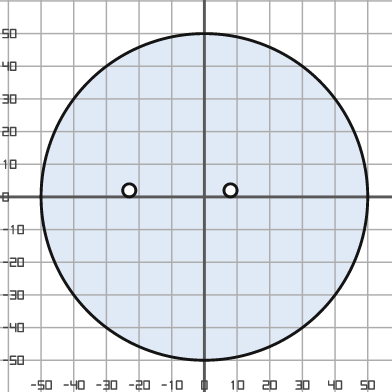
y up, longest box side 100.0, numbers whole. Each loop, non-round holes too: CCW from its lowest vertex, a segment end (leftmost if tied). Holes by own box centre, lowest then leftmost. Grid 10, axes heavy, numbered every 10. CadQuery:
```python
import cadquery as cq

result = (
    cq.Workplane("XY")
    .moveTo(0.0, 0.0)
    .circle(50.0)
    .moveTo(-23.0, 2.0)
    .circle(2.0)
    .moveTo(8.0, 2.0)
    .circle(2.0)
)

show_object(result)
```